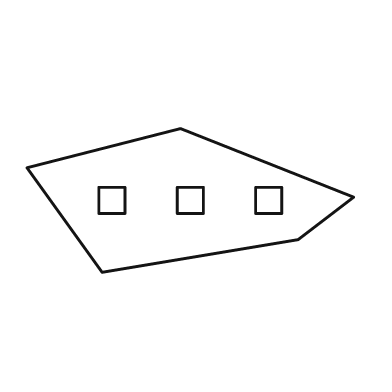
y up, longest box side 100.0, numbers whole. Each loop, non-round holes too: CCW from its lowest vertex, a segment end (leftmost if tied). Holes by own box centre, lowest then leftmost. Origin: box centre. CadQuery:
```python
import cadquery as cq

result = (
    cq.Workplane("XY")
    .moveTo(-27.0, -22.0)
    .lineTo(33.0, -12.0)
    .lineTo(50.0, 1.0)
    .lineTo(-3.0, 22.0)
    .lineTo(-50.0, 10.0)
    .close()
    .moveTo(-28.0, -4.0)
    .lineTo(-20.0, -4.0)
    .lineTo(-20.0, 4.0)
    .lineTo(-28.0, 4.0)
    .close()
    .moveTo(-4.0, -4.0)
    .lineTo(4.0, -4.0)
    .lineTo(4.0, 4.0)
    .lineTo(-4.0, 4.0)
    .close()
    .moveTo(20.0, -4.0)
    .lineTo(28.0, -4.0)
    .lineTo(28.0, 4.0)
    .lineTo(20.0, 4.0)
    .close()
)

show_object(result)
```